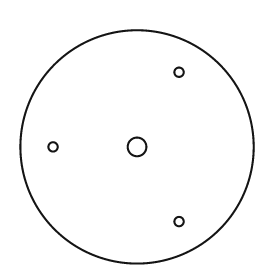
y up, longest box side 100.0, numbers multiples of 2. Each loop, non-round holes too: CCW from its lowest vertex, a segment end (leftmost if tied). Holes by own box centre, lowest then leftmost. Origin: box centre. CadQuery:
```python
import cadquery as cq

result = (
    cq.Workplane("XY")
    .moveTo(0.0, 0.0)
    .circle(50.0)
    .moveTo(18.0, -32.0)
    .circle(2.0)
    .moveTo(-36.0, 0.0)
    .circle(2.0)
    .moveTo(0.0, 0.0)
    .circle(4.0)
    .moveTo(18.0, 32.0)
    .circle(2.0)
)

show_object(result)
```